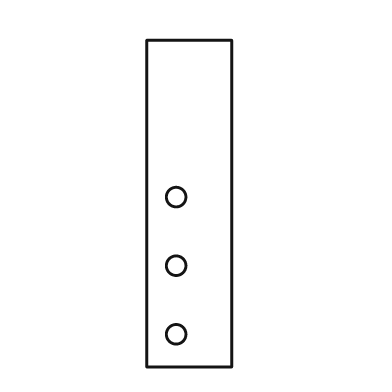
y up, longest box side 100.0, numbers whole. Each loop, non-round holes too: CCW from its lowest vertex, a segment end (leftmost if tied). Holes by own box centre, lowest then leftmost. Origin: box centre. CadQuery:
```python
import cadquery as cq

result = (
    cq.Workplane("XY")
    .moveTo(-13.0, -50.0)
    .lineTo(13.0, -50.0)
    .lineTo(13.0, 50.0)
    .lineTo(-13.0, 50.0)
    .close()
    .moveTo(-4.0, -40.0)
    .circle(3.0)
    .moveTo(-4.0, -19.0)
    .circle(3.0)
    .moveTo(-4.0, 2.0)
    .circle(3.0)
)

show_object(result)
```